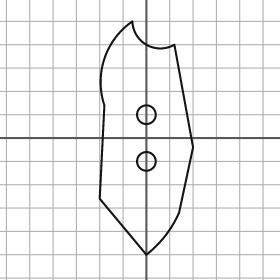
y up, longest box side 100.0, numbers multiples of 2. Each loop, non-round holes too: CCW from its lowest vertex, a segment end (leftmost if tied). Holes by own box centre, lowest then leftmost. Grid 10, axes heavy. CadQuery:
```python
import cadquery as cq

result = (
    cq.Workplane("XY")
    .moveTo(0.0, -50.0)
    .threePointArc((8.0, -42.0), (14.0, -32.0))
    .lineTo(20.0, -4.0)
    .lineTo(12.0, 40.0)
    .threePointArc((0.0, 40.0), (-6.0, 50.0))
    .threePointArc((-18.0, 34.0), (-18.0, 14.0))
    .lineTo(-20.0, -26.0)
    .close()
    .moveTo(0.0, -10.0)
    .circle(4.0)
    .moveTo(0.0, 10.0)
    .circle(4.0)
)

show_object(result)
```